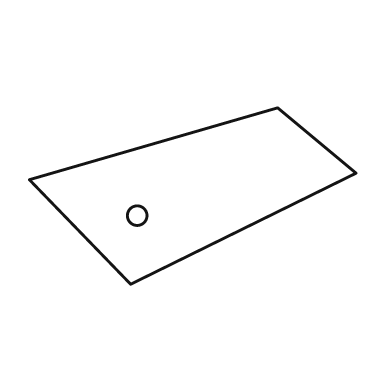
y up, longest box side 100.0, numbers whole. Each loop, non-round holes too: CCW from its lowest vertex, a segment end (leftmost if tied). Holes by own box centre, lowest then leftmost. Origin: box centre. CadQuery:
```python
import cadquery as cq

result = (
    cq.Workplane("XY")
    .moveTo(-19.0, -27.0)
    .lineTo(50.0, 7.0)
    .lineTo(26.0, 27.0)
    .lineTo(-50.0, 5.0)
    .close()
    .moveTo(-17.0, -6.0)
    .circle(3.0)
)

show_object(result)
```